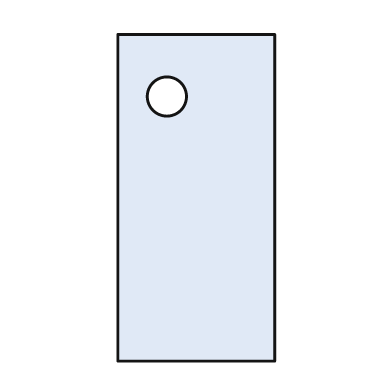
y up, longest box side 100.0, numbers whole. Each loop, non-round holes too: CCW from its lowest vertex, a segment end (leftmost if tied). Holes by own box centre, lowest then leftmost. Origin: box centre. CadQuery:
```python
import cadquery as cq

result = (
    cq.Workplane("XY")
    .moveTo(-24.0, -50.0)
    .lineTo(24.0, -50.0)
    .lineTo(24.0, 50.0)
    .lineTo(-24.0, 50.0)
    .close()
    .moveTo(-9.0, 31.0)
    .circle(6.0)
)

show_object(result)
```